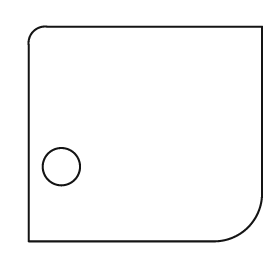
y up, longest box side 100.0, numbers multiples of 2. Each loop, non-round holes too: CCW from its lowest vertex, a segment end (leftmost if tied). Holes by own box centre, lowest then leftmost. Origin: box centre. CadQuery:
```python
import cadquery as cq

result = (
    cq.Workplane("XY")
    .moveTo(-50.0, -46.0)
    .lineTo(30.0, -46.0)
    .threePointArc((44.0, -40.0), (50.0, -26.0))
    .lineTo(50.0, 46.0)
    .lineTo(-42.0, 46.0)
    .threePointArc((-48.0, 44.0), (-50.0, 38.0))
    .close()
    .moveTo(-36.0, -14.0)
    .circle(8.0)
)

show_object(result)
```